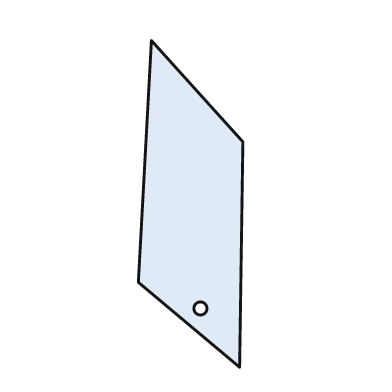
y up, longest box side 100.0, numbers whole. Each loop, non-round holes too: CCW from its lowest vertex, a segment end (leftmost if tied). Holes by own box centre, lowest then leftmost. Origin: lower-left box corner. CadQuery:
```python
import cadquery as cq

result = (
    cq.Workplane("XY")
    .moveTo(31.0, 0.0)
    .lineTo(32.0, 69.0)
    .lineTo(4.0, 100.0)
    .lineTo(0.0, 26.0)
    .close()
    .moveTo(19.0, 18.0)
    .circle(2.0)
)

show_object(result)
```